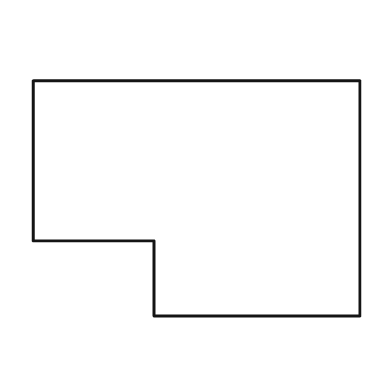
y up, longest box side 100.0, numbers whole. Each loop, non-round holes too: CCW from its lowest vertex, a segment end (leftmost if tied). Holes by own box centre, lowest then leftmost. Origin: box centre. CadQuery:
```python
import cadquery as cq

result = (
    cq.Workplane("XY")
    .moveTo(-13.0, -36.0)
    .lineTo(50.0, -36.0)
    .lineTo(50.0, 36.0)
    .lineTo(-50.0, 36.0)
    .lineTo(-50.0, -13.0)
    .lineTo(-13.0, -13.0)
    .close()
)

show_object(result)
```